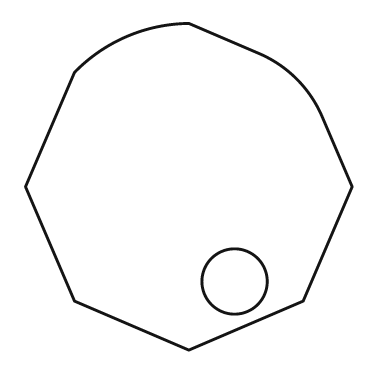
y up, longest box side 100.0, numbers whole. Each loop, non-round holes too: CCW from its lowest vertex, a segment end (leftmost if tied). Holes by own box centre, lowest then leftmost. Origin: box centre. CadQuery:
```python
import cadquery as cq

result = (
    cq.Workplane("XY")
    .moveTo(0.0, -50.0)
    .lineTo(35.0, -35.0)
    .lineTo(50.0, 0.0)
    .lineTo(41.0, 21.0)
    .threePointArc((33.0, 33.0), (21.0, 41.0))
    .lineTo(0.0, 50.0)
    .threePointArc((-19.0, 46.0), (-35.0, 35.0))
    .lineTo(-50.0, 0.0)
    .lineTo(-35.0, -35.0)
    .close()
    .moveTo(14.0, -29.0)
    .circle(10.0)
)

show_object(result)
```